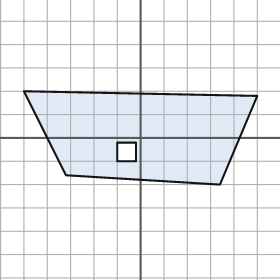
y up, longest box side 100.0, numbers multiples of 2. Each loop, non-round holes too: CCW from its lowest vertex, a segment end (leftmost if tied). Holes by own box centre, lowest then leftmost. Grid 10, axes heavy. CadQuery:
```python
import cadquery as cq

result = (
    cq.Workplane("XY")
    .moveTo(34.0, -20.0)
    .lineTo(50.0, 18.0)
    .lineTo(-50.0, 20.0)
    .lineTo(-32.0, -16.0)
    .close()
    .moveTo(-10.0, -10.0)
    .lineTo(-2.0, -10.0)
    .lineTo(-2.0, -2.0)
    .lineTo(-10.0, -2.0)
    .close()
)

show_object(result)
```